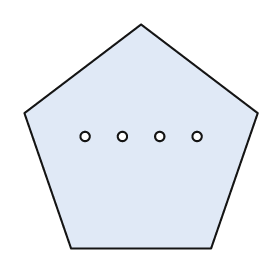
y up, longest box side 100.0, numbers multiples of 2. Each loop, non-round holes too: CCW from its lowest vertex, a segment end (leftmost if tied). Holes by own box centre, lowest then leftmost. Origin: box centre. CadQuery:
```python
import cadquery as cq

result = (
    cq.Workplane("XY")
    .moveTo(-30.0, -48.0)
    .lineTo(30.0, -48.0)
    .lineTo(50.0, 10.0)
    .lineTo(0.0, 48.0)
    .lineTo(-50.0, 10.0)
    .close()
    .moveTo(-24.0, 0.0)
    .circle(2.0)
    .moveTo(-8.0, 0.0)
    .circle(2.0)
    .moveTo(8.0, 0.0)
    .circle(2.0)
    .moveTo(24.0, 0.0)
    .circle(2.0)
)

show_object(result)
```